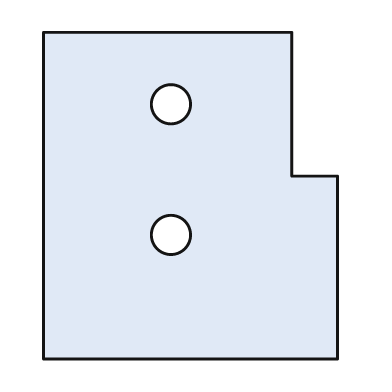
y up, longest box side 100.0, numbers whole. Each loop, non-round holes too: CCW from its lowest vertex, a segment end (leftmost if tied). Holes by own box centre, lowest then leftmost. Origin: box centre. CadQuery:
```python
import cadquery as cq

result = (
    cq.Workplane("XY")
    .moveTo(-45.0, -50.0)
    .lineTo(45.0, -50.0)
    .lineTo(45.0, 6.0)
    .lineTo(31.0, 6.0)
    .lineTo(31.0, 50.0)
    .lineTo(-45.0, 50.0)
    .close()
    .moveTo(-6.0, -12.0)
    .circle(6.0)
    .moveTo(-6.0, 28.0)
    .circle(6.0)
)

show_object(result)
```